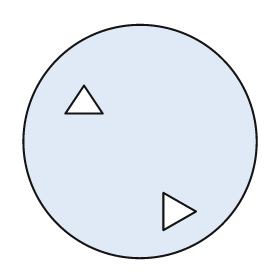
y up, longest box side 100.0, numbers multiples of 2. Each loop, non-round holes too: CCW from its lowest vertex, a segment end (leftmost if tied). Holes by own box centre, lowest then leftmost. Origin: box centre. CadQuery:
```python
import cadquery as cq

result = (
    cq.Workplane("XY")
    .moveTo(0.0, 0.0)
    .circle(50.0)
    .moveTo(10.0, -38.0)
    .lineTo(24.0, -30.0)
    .lineTo(10.0, -22.0)
    .close()
    .moveTo(-32.0, 12.0)
    .lineTo(-16.0, 12.0)
    .lineTo(-24.0, 24.0)
    .close()
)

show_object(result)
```